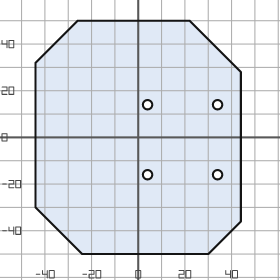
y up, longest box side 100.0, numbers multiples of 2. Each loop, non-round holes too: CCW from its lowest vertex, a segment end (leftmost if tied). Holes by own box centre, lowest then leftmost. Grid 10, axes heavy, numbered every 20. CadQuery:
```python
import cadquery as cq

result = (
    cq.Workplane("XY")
    .moveTo(-24.0, -50.0)
    .lineTo(30.0, -50.0)
    .lineTo(44.0, -36.0)
    .lineTo(44.0, 28.0)
    .lineTo(22.0, 50.0)
    .lineTo(-26.0, 50.0)
    .lineTo(-44.0, 32.0)
    .lineTo(-44.0, -30.0)
    .close()
    .moveTo(4.0, -16.0)
    .circle(2.0)
    .moveTo(34.0, -16.0)
    .circle(2.0)
    .moveTo(4.0, 14.0)
    .circle(2.0)
    .moveTo(34.0, 14.0)
    .circle(2.0)
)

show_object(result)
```